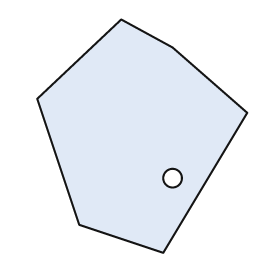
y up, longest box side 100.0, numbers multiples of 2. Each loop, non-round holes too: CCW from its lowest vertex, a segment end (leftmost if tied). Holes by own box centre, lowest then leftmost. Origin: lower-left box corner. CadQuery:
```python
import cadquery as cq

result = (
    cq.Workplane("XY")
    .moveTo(54.0, 0.0)
    .lineTo(90.0, 60.0)
    .lineTo(58.0, 88.0)
    .lineTo(36.0, 100.0)
    .lineTo(0.0, 66.0)
    .lineTo(18.0, 12.0)
    .close()
    .moveTo(58.0, 32.0)
    .circle(4.0)
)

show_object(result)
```